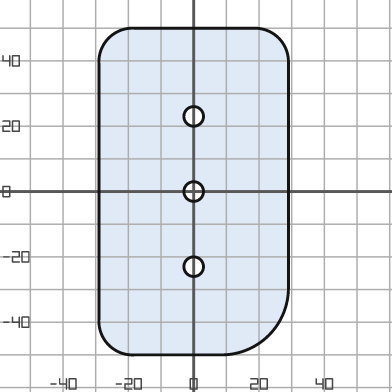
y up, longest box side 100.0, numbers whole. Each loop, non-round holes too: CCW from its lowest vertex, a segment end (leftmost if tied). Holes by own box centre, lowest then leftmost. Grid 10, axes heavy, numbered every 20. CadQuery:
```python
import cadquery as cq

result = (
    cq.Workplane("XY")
    .moveTo(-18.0, -50.0)
    .lineTo(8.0, -50.0)
    .threePointArc((23.0, -44.0), (29.0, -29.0))
    .lineTo(29.0, 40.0)
    .threePointArc((26.0, 47.0), (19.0, 50.0))
    .lineTo(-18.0, 50.0)
    .threePointArc((-26.0, 47.0), (-29.0, 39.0))
    .lineTo(-29.0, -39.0)
    .threePointArc((-26.0, -47.0), (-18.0, -50.0))
    .close()
    .moveTo(0.0, -23.0)
    .circle(3.0)
    .moveTo(0.0, 0.0)
    .circle(3.0)
    .moveTo(0.0, 23.0)
    .circle(3.0)
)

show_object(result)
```